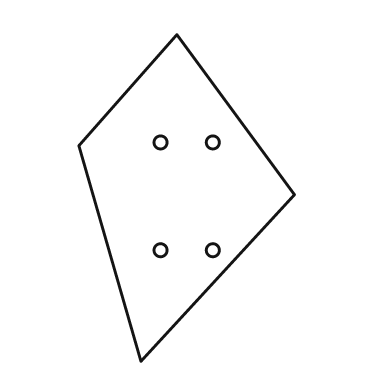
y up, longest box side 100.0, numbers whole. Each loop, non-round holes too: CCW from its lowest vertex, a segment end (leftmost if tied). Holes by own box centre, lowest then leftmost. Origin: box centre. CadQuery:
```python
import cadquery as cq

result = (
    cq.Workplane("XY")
    .moveTo(-14.0, -50.0)
    .lineTo(33.0, 1.0)
    .lineTo(-3.0, 50.0)
    .lineTo(-33.0, 16.0)
    .close()
    .moveTo(-8.0, -16.0)
    .circle(2.0)
    .moveTo(8.0, -16.0)
    .circle(2.0)
    .moveTo(-8.0, 17.0)
    .circle(2.0)
    .moveTo(8.0, 17.0)
    .circle(2.0)
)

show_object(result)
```